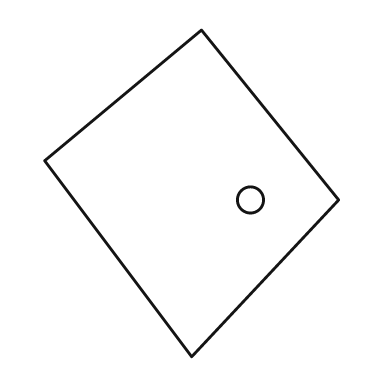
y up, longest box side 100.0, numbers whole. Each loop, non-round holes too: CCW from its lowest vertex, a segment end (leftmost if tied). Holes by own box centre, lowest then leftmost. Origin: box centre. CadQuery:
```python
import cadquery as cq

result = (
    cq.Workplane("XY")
    .moveTo(0.0, -50.0)
    .lineTo(45.0, -2.0)
    .lineTo(3.0, 50.0)
    .lineTo(-45.0, 10.0)
    .close()
    .moveTo(18.0, -2.0)
    .circle(4.0)
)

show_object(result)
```